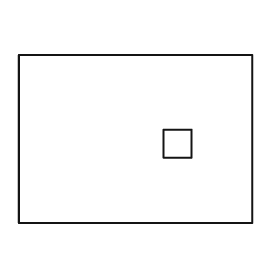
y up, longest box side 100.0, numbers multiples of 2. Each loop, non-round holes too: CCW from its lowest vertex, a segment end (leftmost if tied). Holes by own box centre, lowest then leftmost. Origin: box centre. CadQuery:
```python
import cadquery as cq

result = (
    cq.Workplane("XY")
    .moveTo(-50.0, -36.0)
    .lineTo(50.0, -36.0)
    .lineTo(50.0, 36.0)
    .lineTo(-50.0, 36.0)
    .close()
    .moveTo(12.0, -8.0)
    .lineTo(24.0, -8.0)
    .lineTo(24.0, 4.0)
    .lineTo(12.0, 4.0)
    .close()
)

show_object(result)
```